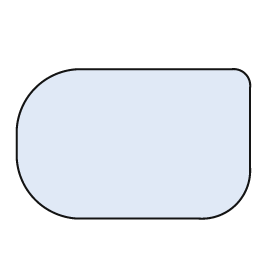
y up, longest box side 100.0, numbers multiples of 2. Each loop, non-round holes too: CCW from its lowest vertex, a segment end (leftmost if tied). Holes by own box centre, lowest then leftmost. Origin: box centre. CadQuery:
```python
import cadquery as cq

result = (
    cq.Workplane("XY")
    .moveTo(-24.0, -32.0)
    .lineTo(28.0, -32.0)
    .threePointArc((44.0, -26.0), (50.0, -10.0))
    .lineTo(50.0, 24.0)
    .threePointArc((48.0, 30.0), (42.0, 32.0))
    .lineTo(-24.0, 32.0)
    .threePointArc((-42.0, 24.0), (-50.0, 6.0))
    .lineTo(-50.0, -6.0)
    .threePointArc((-42.0, -24.0), (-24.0, -32.0))
    .close()
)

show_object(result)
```